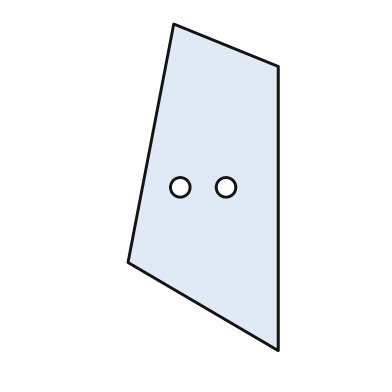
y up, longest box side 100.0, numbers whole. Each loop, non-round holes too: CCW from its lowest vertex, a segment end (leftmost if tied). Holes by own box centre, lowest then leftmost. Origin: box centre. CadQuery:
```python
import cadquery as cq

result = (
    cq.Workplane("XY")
    .moveTo(23.0, -50.0)
    .lineTo(23.0, 37.0)
    .lineTo(-9.0, 50.0)
    .lineTo(-23.0, -23.0)
    .close()
    .moveTo(-7.0, 0.0)
    .circle(3.0)
    .moveTo(7.0, 0.0)
    .circle(3.0)
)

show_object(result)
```